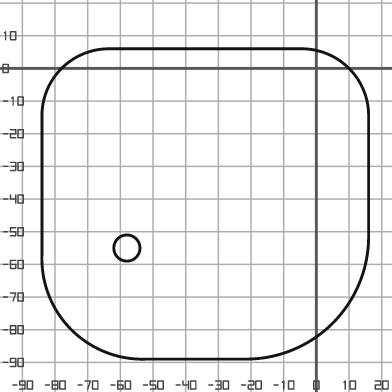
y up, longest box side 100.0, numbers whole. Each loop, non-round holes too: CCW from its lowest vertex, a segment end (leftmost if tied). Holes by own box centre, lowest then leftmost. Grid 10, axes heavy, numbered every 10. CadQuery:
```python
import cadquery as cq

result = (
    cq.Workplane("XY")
    .moveTo(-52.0, -89.0)
    .lineTo(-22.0, -89.0)
    .threePointArc((5.0, -78.0), (16.0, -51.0))
    .lineTo(16.0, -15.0)
    .threePointArc((10.0, 0.0), (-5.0, 6.0))
    .lineTo(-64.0, 6.0)
    .threePointArc((-78.0, 0.0), (-84.0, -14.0))
    .lineTo(-84.0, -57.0)
    .threePointArc((-75.0, -80.0), (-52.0, -89.0))
    .close()
    .moveTo(-58.0, -55.0)
    .circle(4.0)
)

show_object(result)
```